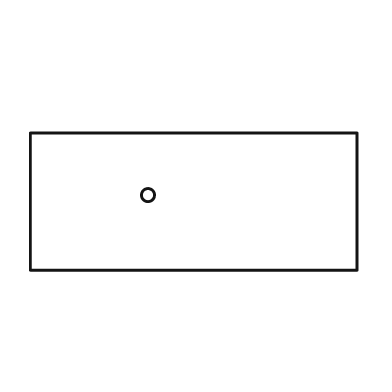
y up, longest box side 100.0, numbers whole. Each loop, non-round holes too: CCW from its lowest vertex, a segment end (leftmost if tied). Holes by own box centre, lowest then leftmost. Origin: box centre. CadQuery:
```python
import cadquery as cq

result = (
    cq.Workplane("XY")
    .moveTo(-50.0, -21.0)
    .lineTo(50.0, -21.0)
    .lineTo(50.0, 21.0)
    .lineTo(-50.0, 21.0)
    .close()
    .moveTo(-14.0, 2.0)
    .circle(2.0)
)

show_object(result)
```